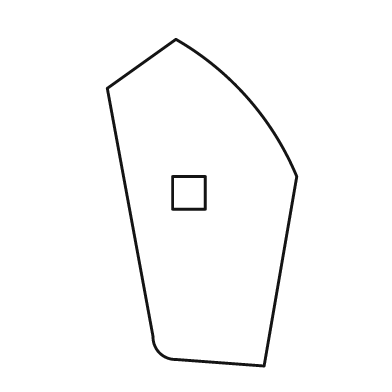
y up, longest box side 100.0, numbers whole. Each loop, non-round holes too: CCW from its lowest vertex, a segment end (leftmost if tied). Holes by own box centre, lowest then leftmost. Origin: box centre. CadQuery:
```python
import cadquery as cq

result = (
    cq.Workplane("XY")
    .moveTo(19.0, -50.0)
    .lineTo(29.0, 8.0)
    .threePointArc((14.0, 32.0), (-8.0, 50.0))
    .lineTo(-29.0, 35.0)
    .lineTo(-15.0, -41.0)
    .threePointArc((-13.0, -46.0), (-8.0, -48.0))
    .close()
    .moveTo(-9.0, -2.0)
    .lineTo(1.0, -2.0)
    .lineTo(1.0, 8.0)
    .lineTo(-9.0, 8.0)
    .close()
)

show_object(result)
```